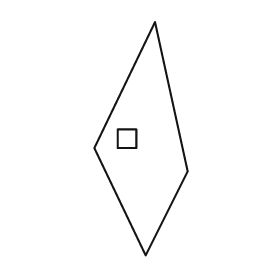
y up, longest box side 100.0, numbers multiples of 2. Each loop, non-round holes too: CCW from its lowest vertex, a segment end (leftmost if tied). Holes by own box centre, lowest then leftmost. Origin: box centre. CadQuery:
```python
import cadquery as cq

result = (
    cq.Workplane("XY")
    .moveTo(2.0, -50.0)
    .lineTo(20.0, -14.0)
    .lineTo(6.0, 50.0)
    .lineTo(-20.0, -4.0)
    .close()
    .moveTo(-10.0, -4.0)
    .lineTo(-2.0, -4.0)
    .lineTo(-2.0, 4.0)
    .lineTo(-10.0, 4.0)
    .close()
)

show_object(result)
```